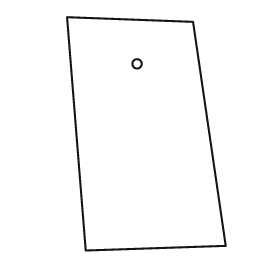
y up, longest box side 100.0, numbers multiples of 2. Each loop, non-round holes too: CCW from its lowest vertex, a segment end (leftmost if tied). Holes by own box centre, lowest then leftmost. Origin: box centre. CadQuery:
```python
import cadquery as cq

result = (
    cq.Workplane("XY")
    .moveTo(-26.0, -50.0)
    .lineTo(34.0, -48.0)
    .lineTo(20.0, 48.0)
    .lineTo(-34.0, 50.0)
    .close()
    .moveTo(-4.0, 30.0)
    .circle(2.0)
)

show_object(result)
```